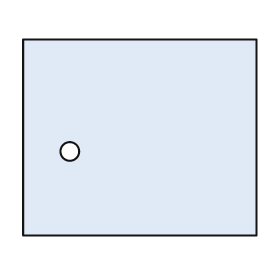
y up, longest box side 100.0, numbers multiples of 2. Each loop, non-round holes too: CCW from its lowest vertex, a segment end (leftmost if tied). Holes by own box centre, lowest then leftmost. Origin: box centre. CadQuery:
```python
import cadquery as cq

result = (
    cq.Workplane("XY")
    .moveTo(-50.0, -42.0)
    .lineTo(50.0, -42.0)
    .lineTo(50.0, 42.0)
    .lineTo(-50.0, 42.0)
    .close()
    .moveTo(-30.0, -6.0)
    .circle(4.0)
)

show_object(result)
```